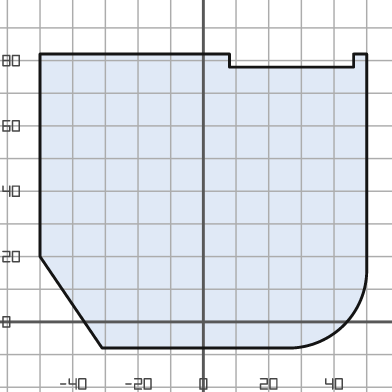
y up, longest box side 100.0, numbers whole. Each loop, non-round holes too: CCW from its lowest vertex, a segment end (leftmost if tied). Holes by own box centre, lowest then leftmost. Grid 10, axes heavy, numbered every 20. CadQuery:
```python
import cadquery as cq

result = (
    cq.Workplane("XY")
    .moveTo(-31.0, -8.0)
    .lineTo(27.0, -8.0)
    .threePointArc((43.0, -1.0), (50.0, 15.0))
    .lineTo(50.0, 82.0)
    .lineTo(46.0, 82.0)
    .lineTo(46.0, 78.0)
    .lineTo(8.0, 78.0)
    .lineTo(8.0, 82.0)
    .lineTo(-50.0, 82.0)
    .lineTo(-50.0, 20.0)
    .close()
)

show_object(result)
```